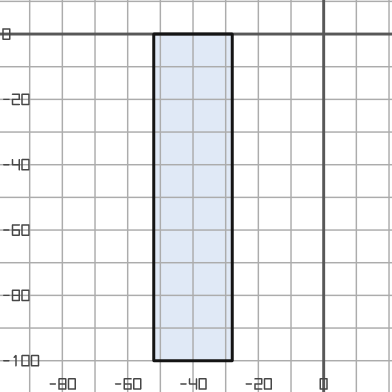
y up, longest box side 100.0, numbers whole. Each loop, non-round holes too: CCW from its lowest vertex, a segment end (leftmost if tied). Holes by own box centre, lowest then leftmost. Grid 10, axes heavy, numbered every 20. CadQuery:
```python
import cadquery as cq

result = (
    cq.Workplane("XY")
    .moveTo(-52.0, -100.0)
    .lineTo(-28.0, -100.0)
    .lineTo(-28.0, 0.0)
    .lineTo(-52.0, 0.0)
    .close()
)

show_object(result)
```